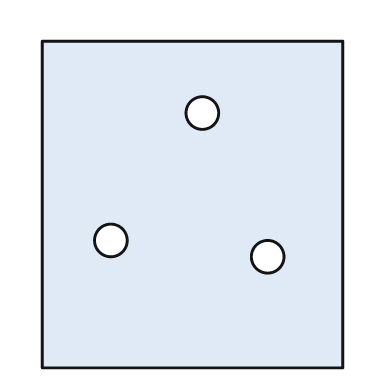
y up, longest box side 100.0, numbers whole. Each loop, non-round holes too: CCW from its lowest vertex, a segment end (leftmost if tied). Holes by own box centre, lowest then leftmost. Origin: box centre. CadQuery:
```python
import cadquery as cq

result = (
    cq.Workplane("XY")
    .moveTo(-46.0, -50.0)
    .lineTo(46.0, -50.0)
    .lineTo(46.0, 50.0)
    .lineTo(-46.0, 50.0)
    .close()
    .moveTo(23.0, -16.0)
    .circle(5.0)
    .moveTo(-25.0, -11.0)
    .circle(5.0)
    .moveTo(3.0, 28.0)
    .circle(5.0)
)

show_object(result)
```